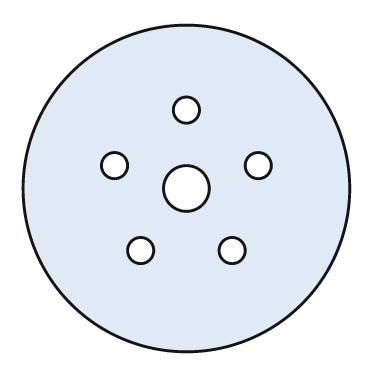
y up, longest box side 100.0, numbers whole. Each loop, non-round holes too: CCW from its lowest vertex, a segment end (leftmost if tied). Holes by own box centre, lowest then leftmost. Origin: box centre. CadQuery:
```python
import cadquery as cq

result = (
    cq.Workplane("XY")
    .moveTo(0.0, 0.0)
    .circle(50.0)
    .moveTo(-14.0, -19.0)
    .circle(4.0)
    .moveTo(14.0, -19.0)
    .circle(4.0)
    .moveTo(0.0, 0.0)
    .circle(7.0)
    .moveTo(-22.0, 7.0)
    .circle(4.0)
    .moveTo(22.0, 7.0)
    .circle(4.0)
    .moveTo(0.0, 24.0)
    .circle(4.0)
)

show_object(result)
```